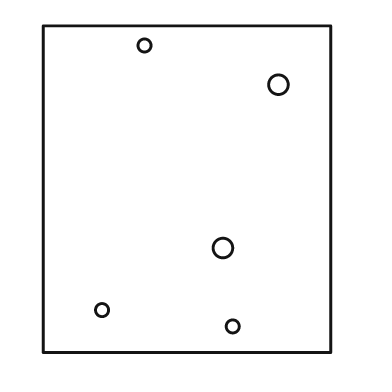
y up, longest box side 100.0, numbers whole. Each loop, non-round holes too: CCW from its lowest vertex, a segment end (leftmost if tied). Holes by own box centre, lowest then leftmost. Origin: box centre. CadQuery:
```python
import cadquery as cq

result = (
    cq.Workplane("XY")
    .moveTo(-44.0, -50.0)
    .lineTo(44.0, -50.0)
    .lineTo(44.0, 50.0)
    .lineTo(-44.0, 50.0)
    .close()
    .moveTo(14.0, -42.0)
    .circle(2.0)
    .moveTo(-26.0, -37.0)
    .circle(2.0)
    .moveTo(11.0, -18.0)
    .circle(3.0)
    .moveTo(28.0, 32.0)
    .circle(3.0)
    .moveTo(-13.0, 44.0)
    .circle(2.0)
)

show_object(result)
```